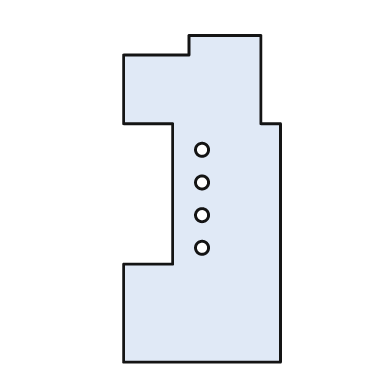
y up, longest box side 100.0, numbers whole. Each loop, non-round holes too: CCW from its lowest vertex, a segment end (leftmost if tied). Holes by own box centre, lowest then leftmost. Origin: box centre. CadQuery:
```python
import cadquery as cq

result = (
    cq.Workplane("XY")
    .moveTo(-24.0, -50.0)
    .lineTo(24.0, -50.0)
    .lineTo(24.0, 23.0)
    .lineTo(18.0, 23.0)
    .lineTo(18.0, 50.0)
    .lineTo(-4.0, 50.0)
    .lineTo(-4.0, 44.0)
    .lineTo(-24.0, 44.0)
    .lineTo(-24.0, 23.0)
    .lineTo(-9.0, 23.0)
    .lineTo(-9.0, -20.0)
    .lineTo(-24.0, -20.0)
    .close()
    .moveTo(0.0, -15.0)
    .circle(2.0)
    .moveTo(0.0, -5.0)
    .circle(2.0)
    .moveTo(0.0, 5.0)
    .circle(2.0)
    .moveTo(0.0, 15.0)
    .circle(2.0)
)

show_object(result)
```